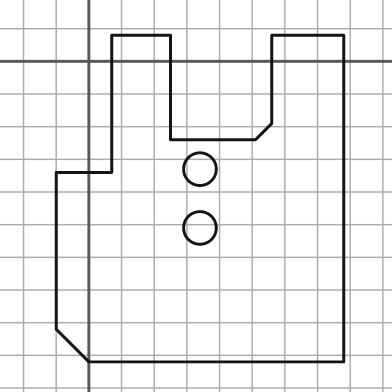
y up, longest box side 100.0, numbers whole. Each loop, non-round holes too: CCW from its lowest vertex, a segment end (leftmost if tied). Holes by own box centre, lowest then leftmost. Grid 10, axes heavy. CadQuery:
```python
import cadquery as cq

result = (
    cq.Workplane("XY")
    .moveTo(0.0, -92.0)
    .lineTo(78.0, -92.0)
    .lineTo(78.0, 8.0)
    .lineTo(56.0, 8.0)
    .lineTo(56.0, -19.0)
    .lineTo(51.0, -24.0)
    .lineTo(25.0, -24.0)
    .lineTo(25.0, 8.0)
    .lineTo(7.0, 8.0)
    .lineTo(7.0, -34.0)
    .lineTo(-10.0, -34.0)
    .lineTo(-10.0, -82.0)
    .close()
    .moveTo(34.0, -51.0)
    .circle(5.0)
    .moveTo(34.0, -33.0)
    .circle(5.0)
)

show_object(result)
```